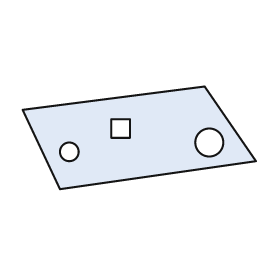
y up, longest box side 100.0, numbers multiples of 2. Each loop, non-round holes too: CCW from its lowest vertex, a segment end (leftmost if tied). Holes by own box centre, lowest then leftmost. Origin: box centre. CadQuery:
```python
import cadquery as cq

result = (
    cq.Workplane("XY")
    .moveTo(-34.0, -22.0)
    .lineTo(50.0, -10.0)
    .lineTo(28.0, 22.0)
    .lineTo(-50.0, 12.0)
    .close()
    .moveTo(-30.0, -6.0)
    .circle(4.0)
    .moveTo(30.0, -2.0)
    .circle(6.0)
    .moveTo(-12.0, 0.0)
    .lineTo(-4.0, 0.0)
    .lineTo(-4.0, 8.0)
    .lineTo(-12.0, 8.0)
    .close()
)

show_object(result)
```